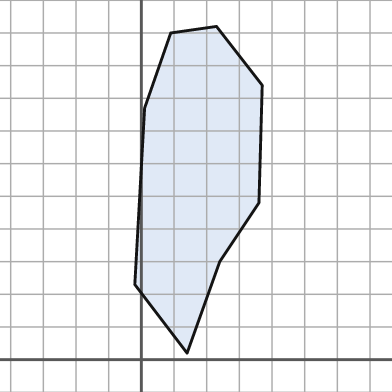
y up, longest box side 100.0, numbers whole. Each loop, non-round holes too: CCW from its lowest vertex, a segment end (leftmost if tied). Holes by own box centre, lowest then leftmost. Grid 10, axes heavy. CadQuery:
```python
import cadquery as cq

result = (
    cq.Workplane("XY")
    .moveTo(14.0, 2.0)
    .lineTo(24.0, 30.0)
    .lineTo(36.0, 48.0)
    .lineTo(37.0, 84.0)
    .lineTo(23.0, 102.0)
    .lineTo(9.0, 100.0)
    .lineTo(1.0, 77.0)
    .lineTo(-2.0, 23.0)
    .close()
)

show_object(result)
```